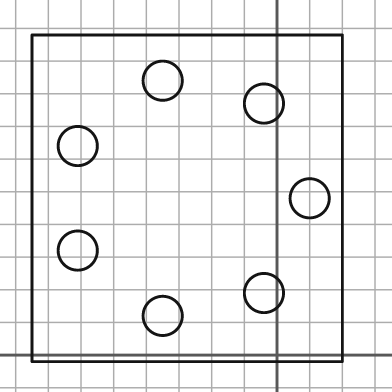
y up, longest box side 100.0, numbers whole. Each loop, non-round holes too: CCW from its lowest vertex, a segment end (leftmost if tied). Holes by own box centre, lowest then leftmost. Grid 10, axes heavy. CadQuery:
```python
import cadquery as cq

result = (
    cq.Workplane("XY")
    .moveTo(-75.0, -2.0)
    .lineTo(20.0, -2.0)
    .lineTo(20.0, 98.0)
    .lineTo(-75.0, 98.0)
    .close()
    .moveTo(-35.0, 12.0)
    .circle(6.0)
    .moveTo(-4.0, 19.0)
    .circle(6.0)
    .moveTo(-61.0, 32.0)
    .circle(6.0)
    .moveTo(10.0, 48.0)
    .circle(6.0)
    .moveTo(-61.0, 64.0)
    .circle(6.0)
    .moveTo(-4.0, 77.0)
    .circle(6.0)
    .moveTo(-35.0, 84.0)
    .circle(6.0)
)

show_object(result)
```